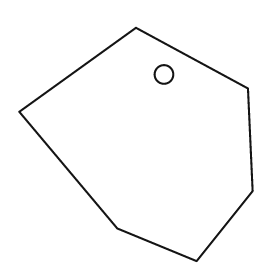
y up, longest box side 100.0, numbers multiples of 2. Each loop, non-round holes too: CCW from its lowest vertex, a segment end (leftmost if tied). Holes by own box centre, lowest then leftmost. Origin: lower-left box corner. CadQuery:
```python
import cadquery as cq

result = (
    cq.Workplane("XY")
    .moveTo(76.0, 0.0)
    .lineTo(100.0, 30.0)
    .lineTo(98.0, 74.0)
    .lineTo(50.0, 100.0)
    .lineTo(0.0, 64.0)
    .lineTo(42.0, 14.0)
    .close()
    .moveTo(62.0, 80.0)
    .circle(4.0)
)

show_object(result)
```